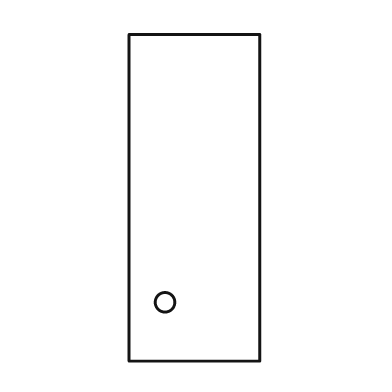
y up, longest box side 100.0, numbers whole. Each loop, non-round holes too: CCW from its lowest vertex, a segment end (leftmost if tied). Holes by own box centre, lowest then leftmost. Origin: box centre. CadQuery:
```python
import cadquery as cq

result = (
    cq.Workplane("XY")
    .moveTo(-20.0, -50.0)
    .lineTo(20.0, -50.0)
    .lineTo(20.0, 50.0)
    .lineTo(-20.0, 50.0)
    .close()
    .moveTo(-9.0, -32.0)
    .circle(3.0)
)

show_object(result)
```